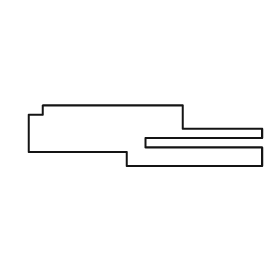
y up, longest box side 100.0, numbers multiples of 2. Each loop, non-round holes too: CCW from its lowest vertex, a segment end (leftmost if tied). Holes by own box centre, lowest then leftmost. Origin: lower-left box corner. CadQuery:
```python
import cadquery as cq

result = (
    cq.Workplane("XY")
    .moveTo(42.0, 0.0)
    .lineTo(100.0, 0.0)
    .lineTo(100.0, 8.0)
    .lineTo(50.0, 8.0)
    .lineTo(50.0, 12.0)
    .lineTo(100.0, 12.0)
    .lineTo(100.0, 16.0)
    .lineTo(66.0, 16.0)
    .lineTo(66.0, 26.0)
    .lineTo(6.0, 26.0)
    .lineTo(6.0, 22.0)
    .lineTo(0.0, 22.0)
    .lineTo(0.0, 6.0)
    .lineTo(42.0, 6.0)
    .close()
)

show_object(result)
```